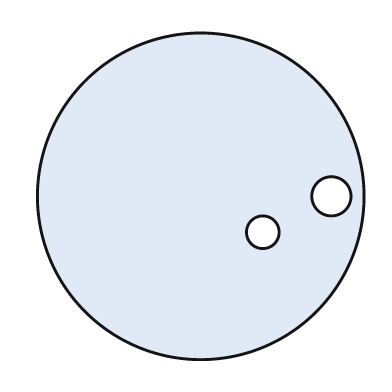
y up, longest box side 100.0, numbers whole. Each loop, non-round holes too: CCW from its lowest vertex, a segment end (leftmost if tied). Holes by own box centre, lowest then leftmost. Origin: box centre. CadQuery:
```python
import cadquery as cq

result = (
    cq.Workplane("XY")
    .moveTo(0.0, 0.0)
    .circle(50.0)
    .moveTo(19.0, -11.0)
    .circle(5.0)
    .moveTo(40.0, 0.0)
    .circle(6.0)
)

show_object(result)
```